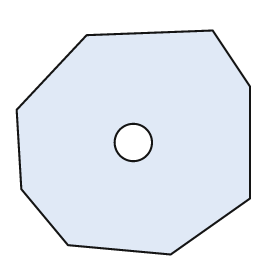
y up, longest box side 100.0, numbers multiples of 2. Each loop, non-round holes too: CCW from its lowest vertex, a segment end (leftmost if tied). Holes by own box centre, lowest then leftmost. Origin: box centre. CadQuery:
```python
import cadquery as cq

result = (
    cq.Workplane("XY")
    .moveTo(16.0, -48.0)
    .lineTo(50.0, -24.0)
    .lineTo(50.0, 24.0)
    .lineTo(34.0, 48.0)
    .lineTo(-20.0, 46.0)
    .lineTo(-50.0, 14.0)
    .lineTo(-48.0, -20.0)
    .lineTo(-28.0, -44.0)
    .close()
    .moveTo(0.0, 0.0)
    .circle(8.0)
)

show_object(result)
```